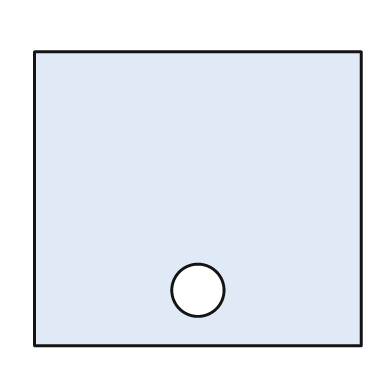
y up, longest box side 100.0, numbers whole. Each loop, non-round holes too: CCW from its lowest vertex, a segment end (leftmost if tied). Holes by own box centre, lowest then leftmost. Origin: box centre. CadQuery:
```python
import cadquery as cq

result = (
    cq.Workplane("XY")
    .moveTo(-50.0, -45.0)
    .lineTo(50.0, -45.0)
    .lineTo(50.0, 45.0)
    .lineTo(-50.0, 45.0)
    .close()
    .moveTo(0.0, -28.0)
    .circle(8.0)
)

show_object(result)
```